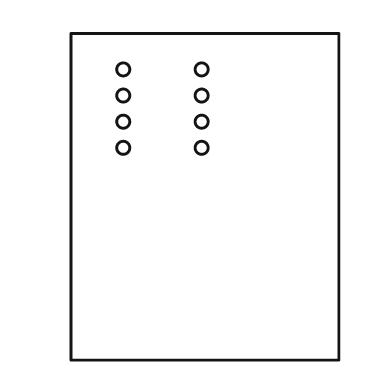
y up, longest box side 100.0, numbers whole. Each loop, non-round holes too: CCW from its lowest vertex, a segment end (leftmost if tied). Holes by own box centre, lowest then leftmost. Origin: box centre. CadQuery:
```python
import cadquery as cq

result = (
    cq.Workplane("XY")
    .moveTo(-41.0, -50.0)
    .lineTo(41.0, -50.0)
    .lineTo(41.0, 50.0)
    .lineTo(-41.0, 50.0)
    .close()
    .moveTo(-25.0, 15.0)
    .circle(2.0)
    .moveTo(-1.0, 15.0)
    .circle(2.0)
    .moveTo(-25.0, 23.0)
    .circle(2.0)
    .moveTo(-1.0, 23.0)
    .circle(2.0)
    .moveTo(-25.0, 31.0)
    .circle(2.0)
    .moveTo(-1.0, 31.0)
    .circle(2.0)
    .moveTo(-25.0, 39.0)
    .circle(2.0)
    .moveTo(-1.0, 39.0)
    .circle(2.0)
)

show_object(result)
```